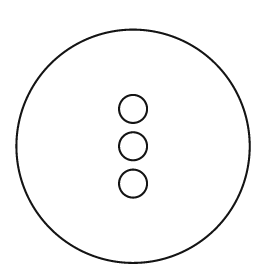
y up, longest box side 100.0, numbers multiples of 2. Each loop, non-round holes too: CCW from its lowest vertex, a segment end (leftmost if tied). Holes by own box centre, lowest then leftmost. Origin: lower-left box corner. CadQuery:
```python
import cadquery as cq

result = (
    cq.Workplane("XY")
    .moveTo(50.0, 50.0)
    .circle(50.0)
    .moveTo(50.0, 34.0)
    .circle(6.0)
    .moveTo(50.0, 50.0)
    .circle(6.0)
    .moveTo(50.0, 66.0)
    .circle(6.0)
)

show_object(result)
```